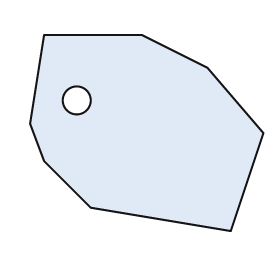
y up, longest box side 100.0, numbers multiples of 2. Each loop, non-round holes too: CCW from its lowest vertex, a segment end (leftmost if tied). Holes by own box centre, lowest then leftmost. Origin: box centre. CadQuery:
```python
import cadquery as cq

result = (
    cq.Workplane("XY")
    .moveTo(36.0, -42.0)
    .lineTo(50.0, 0.0)
    .lineTo(26.0, 28.0)
    .lineTo(-2.0, 42.0)
    .lineTo(-44.0, 42.0)
    .lineTo(-50.0, 4.0)
    .lineTo(-44.0, -12.0)
    .lineTo(-24.0, -32.0)
    .close()
    .moveTo(-30.0, 14.0)
    .circle(6.0)
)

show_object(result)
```